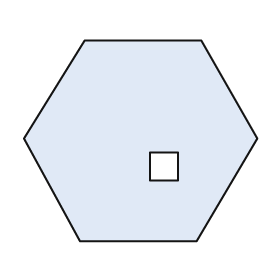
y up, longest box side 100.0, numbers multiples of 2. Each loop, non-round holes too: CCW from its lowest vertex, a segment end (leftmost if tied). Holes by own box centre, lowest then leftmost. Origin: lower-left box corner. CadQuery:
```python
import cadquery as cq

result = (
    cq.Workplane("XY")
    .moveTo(24.0, 0.0)
    .lineTo(74.0, 0.0)
    .lineTo(100.0, 44.0)
    .lineTo(76.0, 86.0)
    .lineTo(26.0, 86.0)
    .lineTo(0.0, 44.0)
    .close()
    .moveTo(54.0, 26.0)
    .lineTo(66.0, 26.0)
    .lineTo(66.0, 38.0)
    .lineTo(54.0, 38.0)
    .close()
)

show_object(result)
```